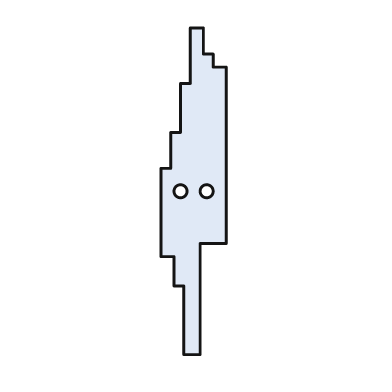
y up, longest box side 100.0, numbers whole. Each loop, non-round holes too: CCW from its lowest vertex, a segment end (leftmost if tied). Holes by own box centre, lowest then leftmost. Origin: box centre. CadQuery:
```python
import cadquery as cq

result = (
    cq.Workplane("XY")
    .moveTo(-3.0, -50.0)
    .lineTo(2.0, -50.0)
    .lineTo(2.0, -16.0)
    .lineTo(10.0, -16.0)
    .lineTo(10.0, 38.0)
    .lineTo(6.0, 38.0)
    .lineTo(6.0, 42.0)
    .lineTo(3.0, 42.0)
    .lineTo(3.0, 50.0)
    .lineTo(-1.0, 50.0)
    .lineTo(-1.0, 33.0)
    .lineTo(-4.0, 33.0)
    .lineTo(-4.0, 18.0)
    .lineTo(-7.0, 18.0)
    .lineTo(-7.0, 7.0)
    .lineTo(-10.0, 7.0)
    .lineTo(-10.0, -20.0)
    .lineTo(-6.0, -20.0)
    .lineTo(-6.0, -29.0)
    .lineTo(-3.0, -29.0)
    .close()
    .moveTo(-4.0, 0.0)
    .circle(2.0)
    .moveTo(4.0, 0.0)
    .circle(2.0)
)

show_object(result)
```